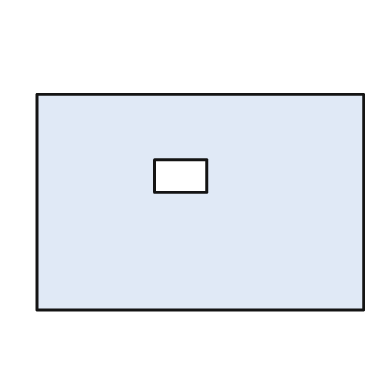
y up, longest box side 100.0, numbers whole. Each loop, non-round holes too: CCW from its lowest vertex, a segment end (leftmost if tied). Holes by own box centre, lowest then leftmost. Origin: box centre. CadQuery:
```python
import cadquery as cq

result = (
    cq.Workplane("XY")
    .moveTo(-50.0, -33.0)
    .lineTo(50.0, -33.0)
    .lineTo(50.0, 33.0)
    .lineTo(-50.0, 33.0)
    .close()
    .moveTo(-14.0, 3.0)
    .lineTo(2.0, 3.0)
    .lineTo(2.0, 13.0)
    .lineTo(-14.0, 13.0)
    .close()
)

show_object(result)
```